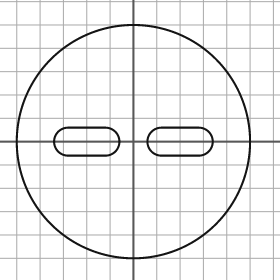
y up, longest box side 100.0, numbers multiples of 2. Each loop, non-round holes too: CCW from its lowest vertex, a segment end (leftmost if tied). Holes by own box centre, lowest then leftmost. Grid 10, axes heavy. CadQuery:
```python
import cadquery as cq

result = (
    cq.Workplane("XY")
    .moveTo(0.0, 0.0)
    .circle(50.0)
    .moveTo(-28.0, -6.0)
    .lineTo(-12.0, -6.0)
    .threePointArc((-6.0, 0.0), (-12.0, 6.0))
    .lineTo(-28.0, 6.0)
    .threePointArc((-34.0, 0.0), (-28.0, -6.0))
    .close()
    .moveTo(12.0, -6.0)
    .lineTo(28.0, -6.0)
    .threePointArc((34.0, 0.0), (28.0, 6.0))
    .lineTo(12.0, 6.0)
    .threePointArc((6.0, 0.0), (12.0, -6.0))
    .close()
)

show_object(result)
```